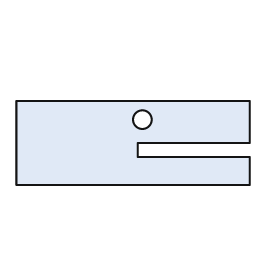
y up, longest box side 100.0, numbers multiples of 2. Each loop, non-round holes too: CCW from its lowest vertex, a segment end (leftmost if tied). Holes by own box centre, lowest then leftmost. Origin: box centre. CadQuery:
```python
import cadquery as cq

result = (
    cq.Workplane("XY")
    .moveTo(-50.0, -18.0)
    .lineTo(50.0, -18.0)
    .lineTo(50.0, -6.0)
    .lineTo(2.0, -6.0)
    .lineTo(2.0, 0.0)
    .lineTo(50.0, 0.0)
    .lineTo(50.0, 18.0)
    .lineTo(-50.0, 18.0)
    .close()
    .moveTo(4.0, 10.0)
    .circle(4.0)
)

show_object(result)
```